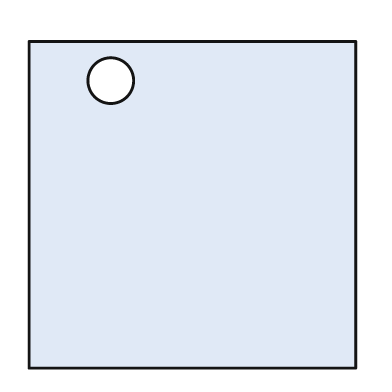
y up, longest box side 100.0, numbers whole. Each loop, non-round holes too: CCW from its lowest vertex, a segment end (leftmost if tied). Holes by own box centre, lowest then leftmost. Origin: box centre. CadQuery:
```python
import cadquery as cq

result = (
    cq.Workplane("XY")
    .moveTo(-50.0, -50.0)
    .lineTo(50.0, -50.0)
    .lineTo(50.0, 50.0)
    .lineTo(-50.0, 50.0)
    .close()
    .moveTo(-25.0, 38.0)
    .circle(7.0)
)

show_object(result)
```